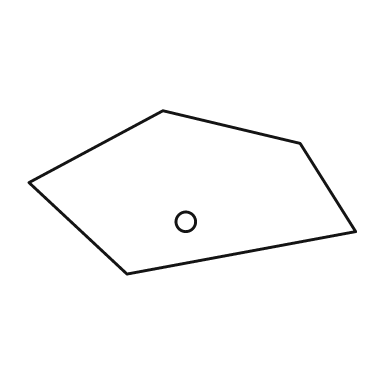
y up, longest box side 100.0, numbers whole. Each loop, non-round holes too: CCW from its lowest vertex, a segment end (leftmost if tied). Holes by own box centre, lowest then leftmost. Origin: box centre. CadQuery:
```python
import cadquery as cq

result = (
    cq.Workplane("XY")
    .moveTo(-20.0, -25.0)
    .lineTo(50.0, -12.0)
    .lineTo(33.0, 15.0)
    .lineTo(-9.0, 25.0)
    .lineTo(-50.0, 3.0)
    .close()
    .moveTo(-2.0, -9.0)
    .circle(3.0)
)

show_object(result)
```